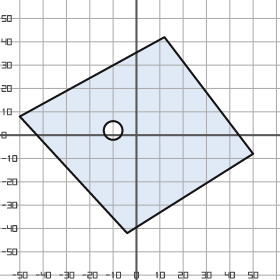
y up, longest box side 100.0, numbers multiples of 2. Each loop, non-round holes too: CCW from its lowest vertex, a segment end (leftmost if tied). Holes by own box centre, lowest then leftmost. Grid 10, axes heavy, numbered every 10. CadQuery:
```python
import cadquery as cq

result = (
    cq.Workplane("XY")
    .moveTo(-4.0, -42.0)
    .lineTo(50.0, -8.0)
    .lineTo(12.0, 42.0)
    .lineTo(-50.0, 8.0)
    .close()
    .moveTo(-10.0, 2.0)
    .circle(4.0)
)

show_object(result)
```